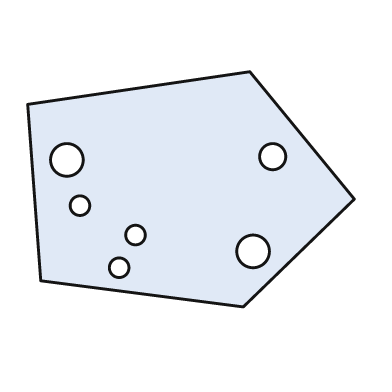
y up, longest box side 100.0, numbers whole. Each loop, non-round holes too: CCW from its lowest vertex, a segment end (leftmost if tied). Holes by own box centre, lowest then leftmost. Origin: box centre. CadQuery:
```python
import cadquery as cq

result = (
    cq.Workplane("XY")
    .moveTo(16.0, -36.0)
    .lineTo(50.0, -3.0)
    .lineTo(18.0, 36.0)
    .lineTo(-50.0, 26.0)
    .lineTo(-46.0, -28.0)
    .close()
    .moveTo(-22.0, -24.0)
    .circle(3.0)
    .moveTo(19.0, -19.0)
    .circle(5.0)
    .moveTo(-17.0, -14.0)
    .circle(3.0)
    .moveTo(-34.0, -5.0)
    .circle(3.0)
    .moveTo(-38.0, 9.0)
    .circle(5.0)
    .moveTo(25.0, 10.0)
    .circle(4.0)
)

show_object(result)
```